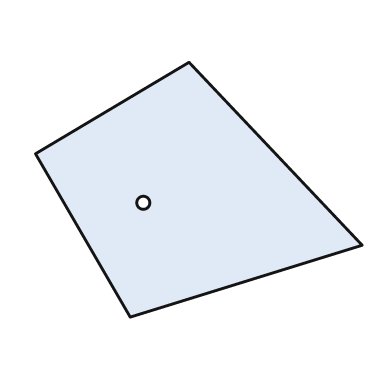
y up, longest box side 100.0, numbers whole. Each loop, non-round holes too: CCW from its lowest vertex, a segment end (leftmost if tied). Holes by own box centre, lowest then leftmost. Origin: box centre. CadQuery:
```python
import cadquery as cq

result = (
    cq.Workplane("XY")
    .moveTo(-21.0, -39.0)
    .lineTo(50.0, -17.0)
    .lineTo(-3.0, 39.0)
    .lineTo(-50.0, 11.0)
    .close()
    .moveTo(-17.0, -4.0)
    .circle(2.0)
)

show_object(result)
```